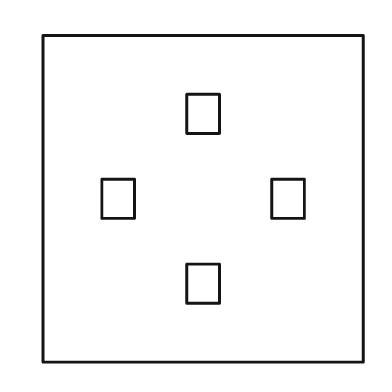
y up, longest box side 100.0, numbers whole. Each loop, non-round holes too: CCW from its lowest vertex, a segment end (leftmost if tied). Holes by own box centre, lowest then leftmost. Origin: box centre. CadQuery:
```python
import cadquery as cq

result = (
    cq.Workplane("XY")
    .moveTo(-49.0, -50.0)
    .lineTo(49.0, -50.0)
    .lineTo(49.0, 50.0)
    .lineTo(-49.0, 50.0)
    .close()
    .moveTo(-5.0, -32.0)
    .lineTo(5.0, -32.0)
    .lineTo(5.0, -20.0)
    .lineTo(-5.0, -20.0)
    .close()
    .moveTo(-31.0, -6.0)
    .lineTo(-21.0, -6.0)
    .lineTo(-21.0, 6.0)
    .lineTo(-31.0, 6.0)
    .close()
    .moveTo(21.0, -6.0)
    .lineTo(31.0, -6.0)
    .lineTo(31.0, 6.0)
    .lineTo(21.0, 6.0)
    .close()
    .moveTo(-5.0, 20.0)
    .lineTo(5.0, 20.0)
    .lineTo(5.0, 32.0)
    .lineTo(-5.0, 32.0)
    .close()
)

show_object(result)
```